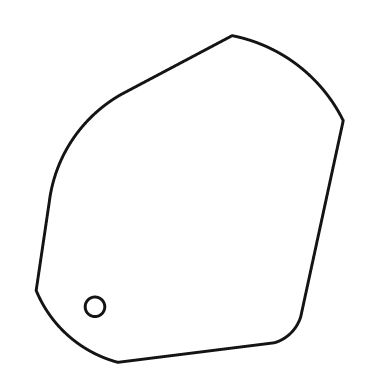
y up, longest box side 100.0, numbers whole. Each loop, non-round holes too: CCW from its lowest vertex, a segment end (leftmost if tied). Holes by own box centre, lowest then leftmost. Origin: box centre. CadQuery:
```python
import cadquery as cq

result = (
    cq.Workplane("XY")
    .moveTo(-22.0, -50.0)
    .lineTo(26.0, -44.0)
    .threePointArc((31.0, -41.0), (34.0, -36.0))
    .lineTo(47.0, 24.0)
    .threePointArc((33.0, 41.0), (13.0, 50.0))
    .lineTo(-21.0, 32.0)
    .threePointArc((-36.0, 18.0), (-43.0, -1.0))
    .lineTo(-47.0, -28.0)
    .threePointArc((-37.0, -42.0), (-22.0, -50.0))
    .close()
    .moveTo(-29.0, -33.0)
    .circle(3.0)
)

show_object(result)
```